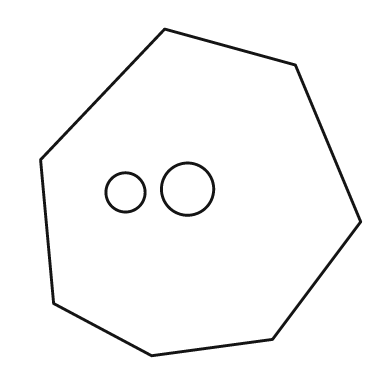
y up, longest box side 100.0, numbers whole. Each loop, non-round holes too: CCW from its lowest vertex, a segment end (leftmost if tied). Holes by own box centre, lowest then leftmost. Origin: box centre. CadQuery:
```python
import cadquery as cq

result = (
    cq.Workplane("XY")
    .moveTo(-15.0, -50.0)
    .lineTo(22.0, -45.0)
    .lineTo(49.0, -9.0)
    .lineTo(29.0, 39.0)
    .lineTo(-11.0, 50.0)
    .lineTo(-49.0, 10.0)
    .lineTo(-45.0, -34.0)
    .close()
    .moveTo(-23.0, 0.0)
    .circle(6.0)
    .moveTo(-4.0, 1.0)
    .circle(8.0)
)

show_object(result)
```